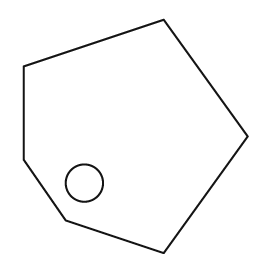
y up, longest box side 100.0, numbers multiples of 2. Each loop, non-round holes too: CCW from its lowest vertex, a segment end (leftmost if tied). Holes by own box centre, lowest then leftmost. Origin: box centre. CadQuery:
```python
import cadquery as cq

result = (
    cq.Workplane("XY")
    .moveTo(12.0, -50.0)
    .lineTo(48.0, 0.0)
    .lineTo(12.0, 50.0)
    .lineTo(-48.0, 30.0)
    .lineTo(-48.0, -10.0)
    .lineTo(-30.0, -36.0)
    .close()
    .moveTo(-22.0, -20.0)
    .circle(8.0)
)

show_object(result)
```